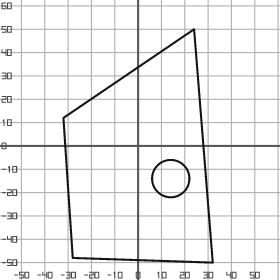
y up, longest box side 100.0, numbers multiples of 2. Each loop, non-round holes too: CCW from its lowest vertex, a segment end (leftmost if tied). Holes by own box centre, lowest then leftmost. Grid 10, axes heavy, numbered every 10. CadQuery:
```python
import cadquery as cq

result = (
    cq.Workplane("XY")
    .moveTo(32.0, -50.0)
    .lineTo(24.0, 50.0)
    .lineTo(-32.0, 12.0)
    .lineTo(-28.0, -48.0)
    .close()
    .moveTo(14.0, -14.0)
    .circle(8.0)
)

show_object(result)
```